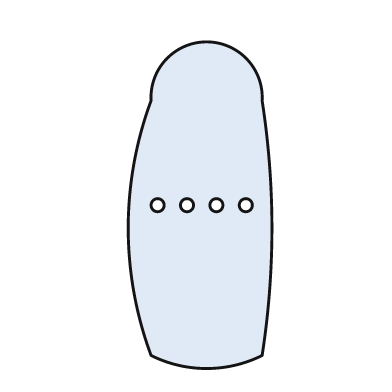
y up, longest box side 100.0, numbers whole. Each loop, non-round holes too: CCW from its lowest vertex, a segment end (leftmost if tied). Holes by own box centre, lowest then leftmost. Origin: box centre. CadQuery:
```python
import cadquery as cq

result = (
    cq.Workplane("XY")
    .moveTo(-15.0, -46.0)
    .threePointArc((2.0, -50.0), (19.0, -46.0))
    .threePointArc((22.0, -7.0), (19.0, 32.0))
    .threePointArc((2.0, 50.0), (-15.0, 32.0))
    .threePointArc((-22.0, -7.0), (-15.0, -46.0))
    .close()
    .moveTo(-13.0, 0.0)
    .circle(2.0)
    .moveTo(-4.0, 0.0)
    .circle(2.0)
    .moveTo(5.0, 0.0)
    .circle(2.0)
    .moveTo(14.0, 0.0)
    .circle(2.0)
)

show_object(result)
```